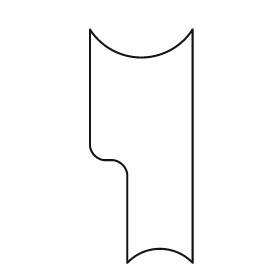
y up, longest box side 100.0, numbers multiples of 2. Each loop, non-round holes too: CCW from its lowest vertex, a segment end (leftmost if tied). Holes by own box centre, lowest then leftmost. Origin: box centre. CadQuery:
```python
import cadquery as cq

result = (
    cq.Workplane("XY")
    .moveTo(-6.0, -50.0)
    .threePointArc((8.0, -44.0), (22.0, -50.0))
    .lineTo(22.0, 50.0)
    .threePointArc((0.0, 38.0), (-22.0, 50.0))
    .lineTo(-22.0, 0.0)
    .threePointArc((-20.0, -4.0), (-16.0, -6.0))
    .lineTo(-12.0, -6.0)
    .threePointArc((-8.0, -8.0), (-6.0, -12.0))
    .close()
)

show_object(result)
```